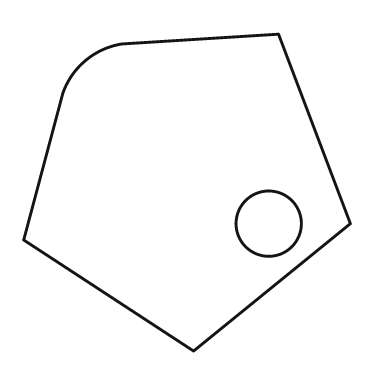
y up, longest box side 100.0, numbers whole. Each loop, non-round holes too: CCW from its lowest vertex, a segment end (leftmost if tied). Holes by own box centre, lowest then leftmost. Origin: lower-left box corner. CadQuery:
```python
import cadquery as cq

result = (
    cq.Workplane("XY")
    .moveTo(52.0, 0.0)
    .lineTo(100.0, 39.0)
    .lineTo(78.0, 97.0)
    .lineTo(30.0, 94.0)
    .threePointArc((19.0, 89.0), (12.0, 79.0))
    .lineTo(0.0, 34.0)
    .close()
    .moveTo(75.0, 39.0)
    .circle(10.0)
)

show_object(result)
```